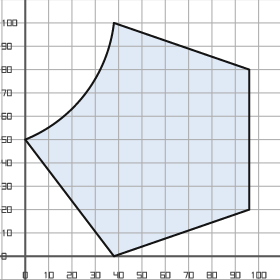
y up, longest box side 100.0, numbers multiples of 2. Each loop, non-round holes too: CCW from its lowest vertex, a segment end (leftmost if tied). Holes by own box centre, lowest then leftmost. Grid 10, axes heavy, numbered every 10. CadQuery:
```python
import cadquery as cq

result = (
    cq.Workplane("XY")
    .moveTo(38.0, 0.0)
    .lineTo(96.0, 20.0)
    .lineTo(96.0, 80.0)
    .lineTo(38.0, 100.0)
    .threePointArc((26.0, 70.0), (0.0, 50.0))
    .close()
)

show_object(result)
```